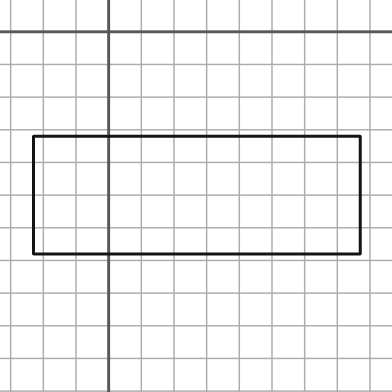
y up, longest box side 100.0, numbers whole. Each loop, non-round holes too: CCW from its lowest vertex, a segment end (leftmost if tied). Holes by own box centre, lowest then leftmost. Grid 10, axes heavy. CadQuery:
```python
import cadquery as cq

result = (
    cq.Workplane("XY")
    .moveTo(-23.0, -68.0)
    .lineTo(77.0, -68.0)
    .lineTo(77.0, -32.0)
    .lineTo(-23.0, -32.0)
    .close()
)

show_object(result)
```